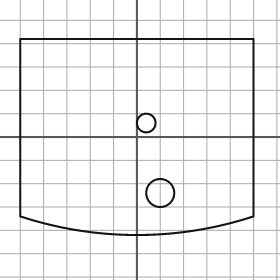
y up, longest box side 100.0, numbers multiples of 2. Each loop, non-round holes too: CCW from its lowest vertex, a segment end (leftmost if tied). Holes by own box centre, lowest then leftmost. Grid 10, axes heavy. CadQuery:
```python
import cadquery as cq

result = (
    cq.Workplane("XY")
    .moveTo(-50.0, -34.0)
    .threePointArc((0.0, -42.0), (50.0, -34.0))
    .lineTo(50.0, 42.0)
    .lineTo(-50.0, 42.0)
    .close()
    .moveTo(10.0, -24.0)
    .circle(6.0)
    .moveTo(4.0, 6.0)
    .circle(4.0)
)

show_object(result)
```